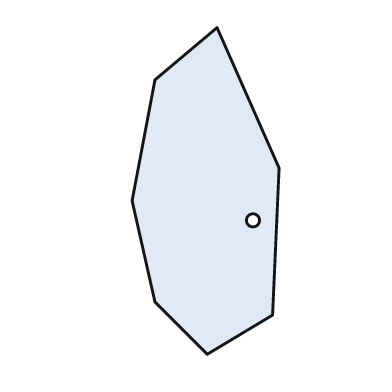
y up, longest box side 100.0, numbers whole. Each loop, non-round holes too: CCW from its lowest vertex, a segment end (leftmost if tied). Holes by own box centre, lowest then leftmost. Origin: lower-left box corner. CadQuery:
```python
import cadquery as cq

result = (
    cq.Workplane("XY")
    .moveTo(23.0, 0.0)
    .lineTo(43.0, 12.0)
    .lineTo(45.0, 57.0)
    .lineTo(26.0, 100.0)
    .lineTo(7.0, 84.0)
    .lineTo(0.0, 47.0)
    .lineTo(7.0, 16.0)
    .close()
    .moveTo(37.0, 41.0)
    .circle(2.0)
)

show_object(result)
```